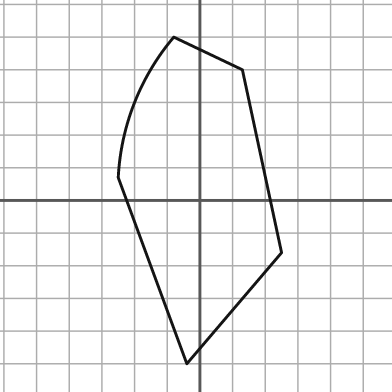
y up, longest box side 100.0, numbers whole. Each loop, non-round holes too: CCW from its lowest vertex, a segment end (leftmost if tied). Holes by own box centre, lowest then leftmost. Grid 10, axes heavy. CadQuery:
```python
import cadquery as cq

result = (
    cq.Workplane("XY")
    .moveTo(-4.0, -50.0)
    .lineTo(25.0, -16.0)
    .lineTo(13.0, 40.0)
    .lineTo(-8.0, 50.0)
    .threePointArc((-20.0, 30.0), (-25.0, 7.0))
    .close()
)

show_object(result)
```